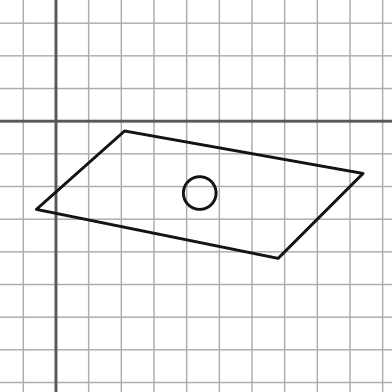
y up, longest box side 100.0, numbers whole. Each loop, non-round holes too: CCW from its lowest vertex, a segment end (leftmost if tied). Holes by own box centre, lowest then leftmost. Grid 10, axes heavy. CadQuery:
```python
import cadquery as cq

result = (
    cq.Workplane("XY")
    .moveTo(68.0, -42.0)
    .lineTo(94.0, -16.0)
    .lineTo(21.0, -3.0)
    .lineTo(-6.0, -27.0)
    .close()
    .moveTo(44.0, -22.0)
    .circle(5.0)
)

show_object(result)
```